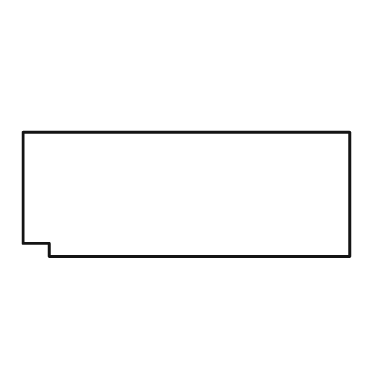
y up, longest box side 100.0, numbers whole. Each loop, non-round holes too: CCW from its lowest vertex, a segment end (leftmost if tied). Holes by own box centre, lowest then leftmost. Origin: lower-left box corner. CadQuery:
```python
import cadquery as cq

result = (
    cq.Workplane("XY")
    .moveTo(8.0, 0.0)
    .lineTo(100.0, 0.0)
    .lineTo(100.0, 38.0)
    .lineTo(0.0, 38.0)
    .lineTo(0.0, 4.0)
    .lineTo(8.0, 4.0)
    .close()
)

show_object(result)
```